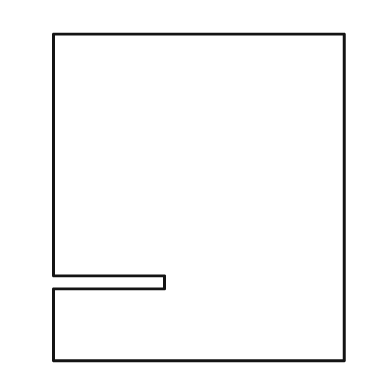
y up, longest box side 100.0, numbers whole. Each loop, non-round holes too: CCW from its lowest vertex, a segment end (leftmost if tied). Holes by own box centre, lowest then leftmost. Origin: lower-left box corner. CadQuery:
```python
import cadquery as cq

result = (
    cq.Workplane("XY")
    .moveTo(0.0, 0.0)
    .lineTo(89.0, 0.0)
    .lineTo(89.0, 100.0)
    .lineTo(0.0, 100.0)
    .lineTo(0.0, 26.0)
    .lineTo(34.0, 26.0)
    .lineTo(34.0, 22.0)
    .lineTo(0.0, 22.0)
    .close()
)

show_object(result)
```